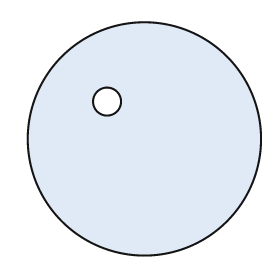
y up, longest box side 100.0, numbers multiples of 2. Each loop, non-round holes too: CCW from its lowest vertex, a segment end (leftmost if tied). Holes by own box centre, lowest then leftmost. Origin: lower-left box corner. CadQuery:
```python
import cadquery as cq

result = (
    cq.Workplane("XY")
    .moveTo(50.0, 50.0)
    .circle(50.0)
    .moveTo(34.0, 66.0)
    .circle(6.0)
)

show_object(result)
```